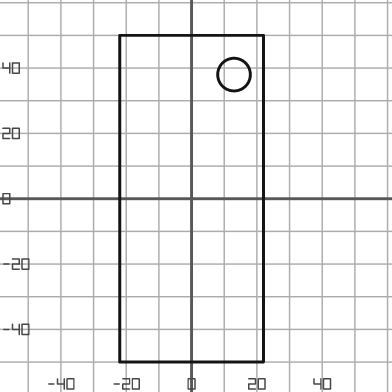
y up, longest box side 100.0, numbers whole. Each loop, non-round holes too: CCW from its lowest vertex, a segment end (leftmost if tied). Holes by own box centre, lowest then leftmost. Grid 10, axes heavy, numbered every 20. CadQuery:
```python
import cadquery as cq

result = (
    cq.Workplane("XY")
    .moveTo(-22.0, -50.0)
    .lineTo(22.0, -50.0)
    .lineTo(22.0, 50.0)
    .lineTo(-22.0, 50.0)
    .close()
    .moveTo(13.0, 38.0)
    .circle(5.0)
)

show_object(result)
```